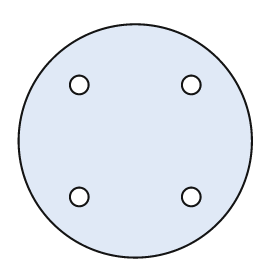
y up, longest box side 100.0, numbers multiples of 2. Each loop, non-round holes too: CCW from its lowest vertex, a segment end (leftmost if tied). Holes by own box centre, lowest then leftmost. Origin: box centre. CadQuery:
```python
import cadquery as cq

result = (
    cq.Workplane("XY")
    .moveTo(0.0, 0.0)
    .circle(50.0)
    .moveTo(-24.0, -24.0)
    .circle(4.0)
    .moveTo(24.0, -24.0)
    .circle(4.0)
    .moveTo(-24.0, 24.0)
    .circle(4.0)
    .moveTo(24.0, 24.0)
    .circle(4.0)
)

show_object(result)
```